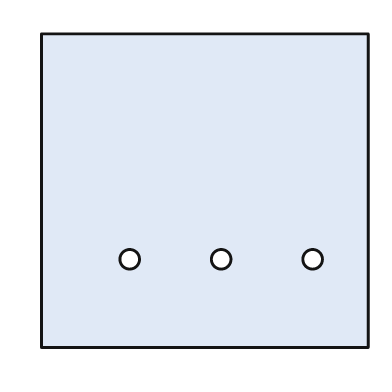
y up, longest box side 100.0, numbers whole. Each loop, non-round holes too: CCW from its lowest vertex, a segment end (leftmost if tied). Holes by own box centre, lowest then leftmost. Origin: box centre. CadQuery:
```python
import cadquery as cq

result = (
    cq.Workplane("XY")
    .moveTo(-50.0, -48.0)
    .lineTo(50.0, -48.0)
    .lineTo(50.0, 48.0)
    .lineTo(-50.0, 48.0)
    .close()
    .moveTo(-23.0, -21.0)
    .circle(3.0)
    .moveTo(5.0, -21.0)
    .circle(3.0)
    .moveTo(33.0, -21.0)
    .circle(3.0)
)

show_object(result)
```